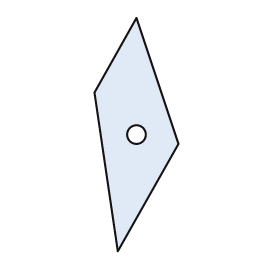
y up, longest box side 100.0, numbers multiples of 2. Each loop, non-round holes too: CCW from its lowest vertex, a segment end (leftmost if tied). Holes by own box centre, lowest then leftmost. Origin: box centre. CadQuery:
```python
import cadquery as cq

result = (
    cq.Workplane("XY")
    .moveTo(-8.0, -50.0)
    .lineTo(18.0, -4.0)
    .lineTo(0.0, 50.0)
    .lineTo(-18.0, 18.0)
    .close()
    .moveTo(0.0, 0.0)
    .circle(4.0)
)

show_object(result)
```